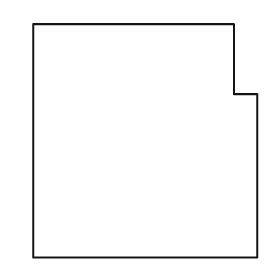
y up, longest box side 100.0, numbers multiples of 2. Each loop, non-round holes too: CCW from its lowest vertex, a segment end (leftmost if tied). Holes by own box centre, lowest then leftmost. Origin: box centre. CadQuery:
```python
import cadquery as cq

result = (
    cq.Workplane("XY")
    .moveTo(-48.0, -50.0)
    .lineTo(48.0, -50.0)
    .lineTo(48.0, 20.0)
    .lineTo(38.0, 20.0)
    .lineTo(38.0, 50.0)
    .lineTo(-48.0, 50.0)
    .close()
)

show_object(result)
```